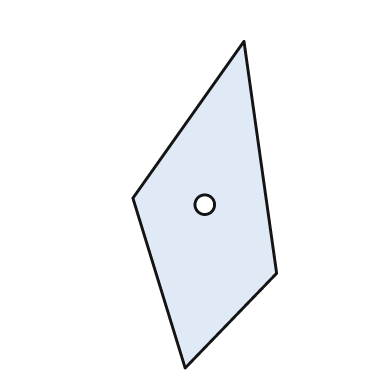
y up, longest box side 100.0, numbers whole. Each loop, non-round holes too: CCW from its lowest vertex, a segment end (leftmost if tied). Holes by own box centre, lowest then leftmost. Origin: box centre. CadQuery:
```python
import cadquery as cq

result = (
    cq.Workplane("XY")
    .moveTo(-6.0, -50.0)
    .lineTo(22.0, -21.0)
    .lineTo(12.0, 50.0)
    .lineTo(-22.0, 2.0)
    .close()
    .moveTo(0.0, 0.0)
    .circle(3.0)
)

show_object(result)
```